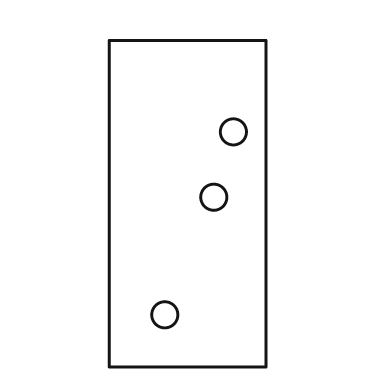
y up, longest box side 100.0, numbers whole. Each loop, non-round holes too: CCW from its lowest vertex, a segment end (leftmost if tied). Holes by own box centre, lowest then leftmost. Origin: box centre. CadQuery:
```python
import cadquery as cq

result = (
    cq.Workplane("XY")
    .moveTo(-24.0, -50.0)
    .lineTo(24.0, -50.0)
    .lineTo(24.0, 50.0)
    .lineTo(-24.0, 50.0)
    .close()
    .moveTo(-7.0, -34.0)
    .circle(4.0)
    .moveTo(8.0, 2.0)
    .circle(4.0)
    .moveTo(14.0, 22.0)
    .circle(4.0)
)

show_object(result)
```